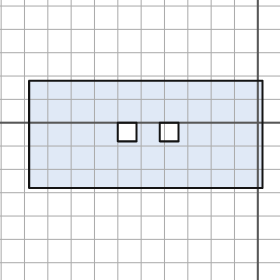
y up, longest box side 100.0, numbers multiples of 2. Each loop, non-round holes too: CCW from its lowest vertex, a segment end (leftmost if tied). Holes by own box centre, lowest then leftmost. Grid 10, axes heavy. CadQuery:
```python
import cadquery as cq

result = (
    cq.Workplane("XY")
    .moveTo(-98.0, -28.0)
    .lineTo(2.0, -28.0)
    .lineTo(2.0, 18.0)
    .lineTo(-98.0, 18.0)
    .close()
    .moveTo(-60.0, -8.0)
    .lineTo(-52.0, -8.0)
    .lineTo(-52.0, 0.0)
    .lineTo(-60.0, 0.0)
    .close()
    .moveTo(-42.0, -8.0)
    .lineTo(-34.0, -8.0)
    .lineTo(-34.0, 0.0)
    .lineTo(-42.0, 0.0)
    .close()
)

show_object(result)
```